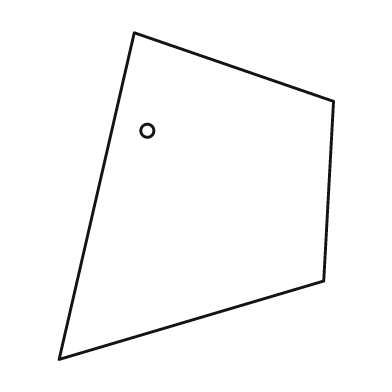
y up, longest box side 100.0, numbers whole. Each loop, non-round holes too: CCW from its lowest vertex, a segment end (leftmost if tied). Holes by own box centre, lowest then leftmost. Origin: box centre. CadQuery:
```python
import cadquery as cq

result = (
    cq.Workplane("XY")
    .moveTo(-42.0, -50.0)
    .lineTo(39.0, -26.0)
    .lineTo(42.0, 29.0)
    .lineTo(-19.0, 50.0)
    .close()
    .moveTo(-15.0, 20.0)
    .circle(2.0)
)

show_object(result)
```